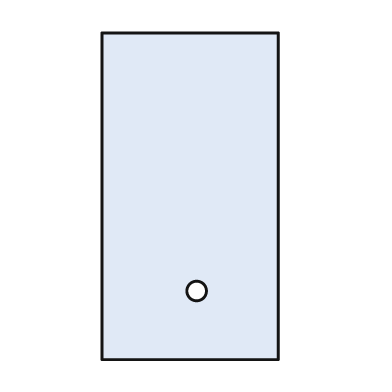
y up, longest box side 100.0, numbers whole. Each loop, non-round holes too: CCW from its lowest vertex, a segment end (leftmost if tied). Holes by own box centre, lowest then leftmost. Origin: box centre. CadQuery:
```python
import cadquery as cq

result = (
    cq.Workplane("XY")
    .moveTo(-27.0, -50.0)
    .lineTo(27.0, -50.0)
    .lineTo(27.0, 50.0)
    .lineTo(-27.0, 50.0)
    .close()
    .moveTo(2.0, -29.0)
    .circle(3.0)
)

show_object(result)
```